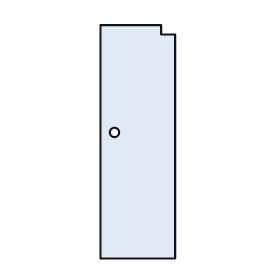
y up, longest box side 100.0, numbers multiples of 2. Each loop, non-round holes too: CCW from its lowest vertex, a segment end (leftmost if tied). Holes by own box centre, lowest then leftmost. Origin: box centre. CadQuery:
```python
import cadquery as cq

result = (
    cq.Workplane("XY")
    .moveTo(-16.0, -50.0)
    .lineTo(16.0, -50.0)
    .lineTo(16.0, 46.0)
    .lineTo(10.0, 46.0)
    .lineTo(10.0, 50.0)
    .lineTo(-16.0, 50.0)
    .close()
    .moveTo(-10.0, 4.0)
    .circle(2.0)
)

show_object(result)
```